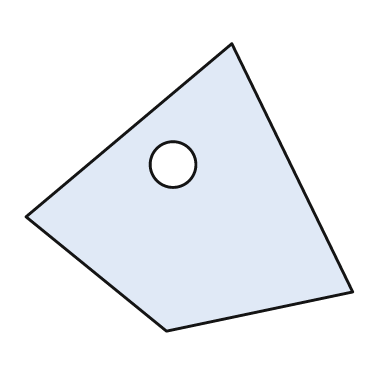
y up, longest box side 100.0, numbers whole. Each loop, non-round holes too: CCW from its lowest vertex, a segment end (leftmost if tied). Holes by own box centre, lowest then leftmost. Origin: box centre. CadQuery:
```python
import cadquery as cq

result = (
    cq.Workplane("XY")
    .moveTo(-7.0, -44.0)
    .lineTo(50.0, -32.0)
    .lineTo(13.0, 44.0)
    .lineTo(-50.0, -9.0)
    .close()
    .moveTo(-5.0, 7.0)
    .circle(7.0)
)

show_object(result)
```